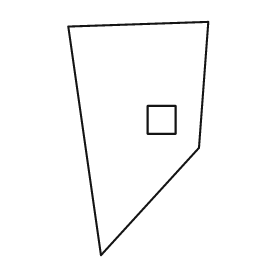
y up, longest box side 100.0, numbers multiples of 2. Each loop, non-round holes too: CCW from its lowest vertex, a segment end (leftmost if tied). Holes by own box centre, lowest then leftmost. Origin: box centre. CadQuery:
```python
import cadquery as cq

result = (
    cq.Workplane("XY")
    .moveTo(-16.0, -50.0)
    .lineTo(26.0, -4.0)
    .lineTo(30.0, 50.0)
    .lineTo(-30.0, 48.0)
    .close()
    .moveTo(4.0, 2.0)
    .lineTo(16.0, 2.0)
    .lineTo(16.0, 14.0)
    .lineTo(4.0, 14.0)
    .close()
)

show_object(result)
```